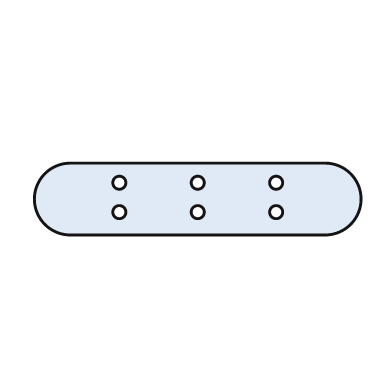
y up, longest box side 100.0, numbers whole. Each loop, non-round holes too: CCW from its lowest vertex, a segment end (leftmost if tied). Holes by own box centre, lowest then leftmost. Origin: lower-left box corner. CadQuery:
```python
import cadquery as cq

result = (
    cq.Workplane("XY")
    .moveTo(11.0, 0.0)
    .lineTo(89.0, 0.0)
    .threePointArc((100.0, 11.0), (89.0, 22.0))
    .lineTo(11.0, 22.0)
    .threePointArc((0.0, 11.0), (11.0, 0.0))
    .close()
    .moveTo(26.0, 7.0)
    .circle(2.0)
    .moveTo(50.0, 7.0)
    .circle(2.0)
    .moveTo(74.0, 7.0)
    .circle(2.0)
    .moveTo(26.0, 16.0)
    .circle(2.0)
    .moveTo(50.0, 16.0)
    .circle(2.0)
    .moveTo(74.0, 16.0)
    .circle(2.0)
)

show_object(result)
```